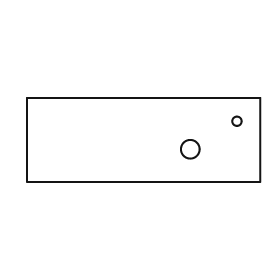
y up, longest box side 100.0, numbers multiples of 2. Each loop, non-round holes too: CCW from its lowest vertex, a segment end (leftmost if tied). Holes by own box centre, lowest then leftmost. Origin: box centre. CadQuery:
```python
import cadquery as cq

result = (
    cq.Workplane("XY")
    .moveTo(-50.0, -18.0)
    .lineTo(50.0, -18.0)
    .lineTo(50.0, 18.0)
    .lineTo(-50.0, 18.0)
    .close()
    .moveTo(20.0, -4.0)
    .circle(4.0)
    .moveTo(40.0, 8.0)
    .circle(2.0)
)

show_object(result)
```